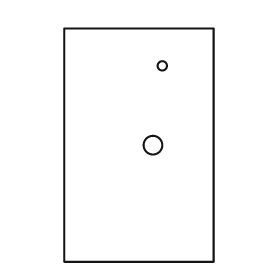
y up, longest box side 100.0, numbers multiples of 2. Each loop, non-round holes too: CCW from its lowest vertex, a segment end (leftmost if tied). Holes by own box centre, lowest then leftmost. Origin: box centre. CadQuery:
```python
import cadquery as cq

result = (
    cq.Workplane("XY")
    .moveTo(-32.0, -50.0)
    .lineTo(32.0, -50.0)
    .lineTo(32.0, 50.0)
    .lineTo(-32.0, 50.0)
    .close()
    .moveTo(6.0, 0.0)
    .circle(4.0)
    .moveTo(10.0, 34.0)
    .circle(2.0)
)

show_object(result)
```